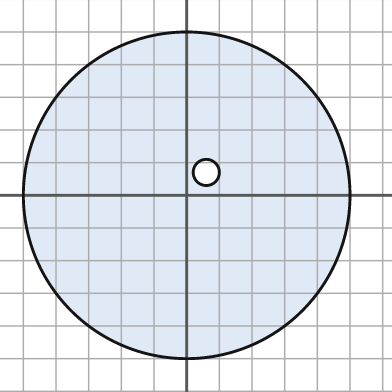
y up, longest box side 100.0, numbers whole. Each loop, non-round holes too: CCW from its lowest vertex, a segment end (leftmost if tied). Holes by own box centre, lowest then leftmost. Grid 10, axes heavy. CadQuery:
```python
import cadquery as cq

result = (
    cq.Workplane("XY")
    .moveTo(0.0, 0.0)
    .circle(50.0)
    .moveTo(6.0, 7.0)
    .circle(4.0)
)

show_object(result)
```